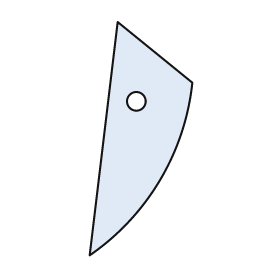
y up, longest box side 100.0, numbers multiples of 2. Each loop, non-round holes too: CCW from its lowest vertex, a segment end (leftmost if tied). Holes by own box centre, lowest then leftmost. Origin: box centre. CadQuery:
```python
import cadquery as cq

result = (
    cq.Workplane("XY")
    .moveTo(-22.0, -50.0)
    .threePointArc((8.0, -18.0), (22.0, 24.0))
    .lineTo(-10.0, 50.0)
    .close()
    .moveTo(-2.0, 16.0)
    .circle(4.0)
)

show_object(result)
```